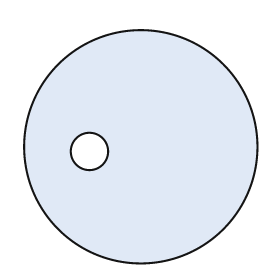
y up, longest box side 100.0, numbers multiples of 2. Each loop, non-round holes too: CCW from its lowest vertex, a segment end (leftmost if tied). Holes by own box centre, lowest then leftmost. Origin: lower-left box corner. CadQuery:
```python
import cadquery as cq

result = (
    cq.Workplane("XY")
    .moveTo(50.0, 50.0)
    .circle(50.0)
    .moveTo(28.0, 48.0)
    .circle(8.0)
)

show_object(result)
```